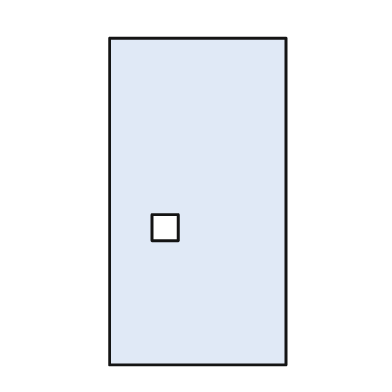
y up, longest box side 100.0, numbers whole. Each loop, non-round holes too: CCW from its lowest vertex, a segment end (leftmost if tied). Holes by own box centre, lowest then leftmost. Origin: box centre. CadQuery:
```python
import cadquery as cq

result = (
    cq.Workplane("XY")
    .moveTo(-27.0, -50.0)
    .lineTo(27.0, -50.0)
    .lineTo(27.0, 50.0)
    .lineTo(-27.0, 50.0)
    .close()
    .moveTo(-14.0, -12.0)
    .lineTo(-6.0, -12.0)
    .lineTo(-6.0, -4.0)
    .lineTo(-14.0, -4.0)
    .close()
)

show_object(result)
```